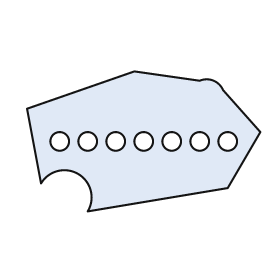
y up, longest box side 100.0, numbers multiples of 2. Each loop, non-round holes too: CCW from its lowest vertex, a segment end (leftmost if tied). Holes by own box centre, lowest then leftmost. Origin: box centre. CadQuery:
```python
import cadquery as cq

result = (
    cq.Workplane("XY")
    .moveTo(-24.0, -30.0)
    .lineTo(36.0, -20.0)
    .lineTo(50.0, 4.0)
    .lineTo(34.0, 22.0)
    .threePointArc((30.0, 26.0), (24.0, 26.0))
    .lineTo(-4.0, 30.0)
    .lineTo(-50.0, 14.0)
    .lineTo(-44.0, -18.0)
    .threePointArc((-28.0, -14.0), (-24.0, -30.0))
    .close()
    .moveTo(-36.0, 0.0)
    .circle(4.0)
    .moveTo(-24.0, 0.0)
    .circle(4.0)
    .moveTo(-12.0, 0.0)
    .circle(4.0)
    .moveTo(0.0, 0.0)
    .circle(4.0)
    .moveTo(12.0, 0.0)
    .circle(4.0)
    .moveTo(24.0, 0.0)
    .circle(4.0)
    .moveTo(36.0, 0.0)
    .circle(4.0)
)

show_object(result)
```